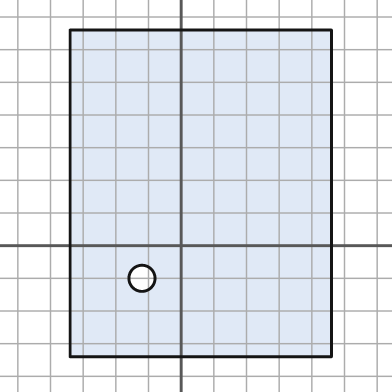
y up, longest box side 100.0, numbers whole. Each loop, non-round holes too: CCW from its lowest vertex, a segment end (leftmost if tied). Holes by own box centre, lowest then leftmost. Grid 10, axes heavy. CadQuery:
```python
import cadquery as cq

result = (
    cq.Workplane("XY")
    .moveTo(-34.0, -34.0)
    .lineTo(46.0, -34.0)
    .lineTo(46.0, 66.0)
    .lineTo(-34.0, 66.0)
    .close()
    .moveTo(-12.0, -10.0)
    .circle(4.0)
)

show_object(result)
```